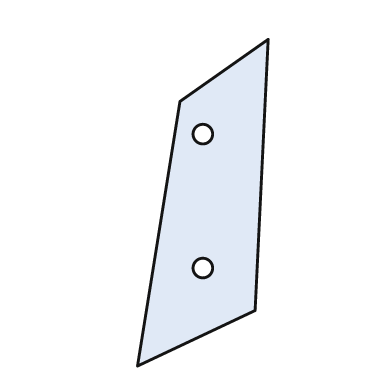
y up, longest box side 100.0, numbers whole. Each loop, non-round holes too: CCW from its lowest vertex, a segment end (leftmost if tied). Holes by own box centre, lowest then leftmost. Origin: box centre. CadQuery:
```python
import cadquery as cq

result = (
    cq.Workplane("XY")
    .moveTo(-20.0, -50.0)
    .lineTo(16.0, -33.0)
    .lineTo(20.0, 50.0)
    .lineTo(-7.0, 31.0)
    .close()
    .moveTo(0.0, -20.0)
    .circle(3.0)
    .moveTo(0.0, 21.0)
    .circle(3.0)
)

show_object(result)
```